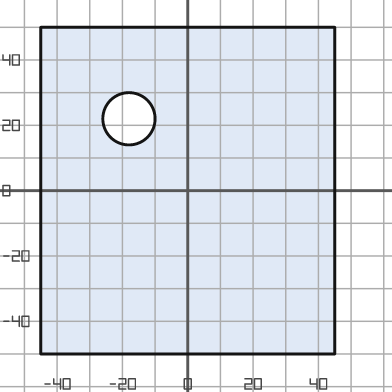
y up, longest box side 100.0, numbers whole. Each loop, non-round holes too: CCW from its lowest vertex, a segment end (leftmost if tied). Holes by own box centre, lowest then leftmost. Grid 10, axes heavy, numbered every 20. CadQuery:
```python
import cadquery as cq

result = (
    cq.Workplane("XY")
    .moveTo(-45.0, -50.0)
    .lineTo(45.0, -50.0)
    .lineTo(45.0, 50.0)
    .lineTo(-45.0, 50.0)
    .close()
    .moveTo(-18.0, 22.0)
    .circle(8.0)
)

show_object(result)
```